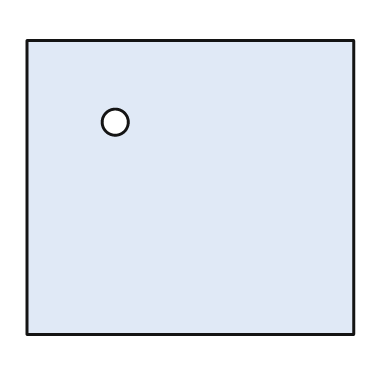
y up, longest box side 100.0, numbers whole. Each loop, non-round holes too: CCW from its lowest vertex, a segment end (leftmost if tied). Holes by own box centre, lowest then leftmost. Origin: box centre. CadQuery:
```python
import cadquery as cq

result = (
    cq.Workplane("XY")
    .moveTo(-50.0, -45.0)
    .lineTo(50.0, -45.0)
    .lineTo(50.0, 45.0)
    .lineTo(-50.0, 45.0)
    .close()
    .moveTo(-23.0, 20.0)
    .circle(4.0)
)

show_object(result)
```